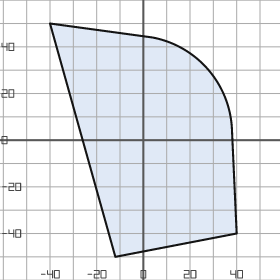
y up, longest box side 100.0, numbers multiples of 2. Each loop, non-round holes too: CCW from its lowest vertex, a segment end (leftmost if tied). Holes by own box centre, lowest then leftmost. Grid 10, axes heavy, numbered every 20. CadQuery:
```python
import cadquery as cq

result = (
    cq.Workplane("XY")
    .moveTo(-12.0, -50.0)
    .lineTo(40.0, -40.0)
    .lineTo(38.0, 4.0)
    .threePointArc((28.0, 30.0), (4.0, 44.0))
    .lineTo(-40.0, 50.0)
    .close()
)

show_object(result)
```